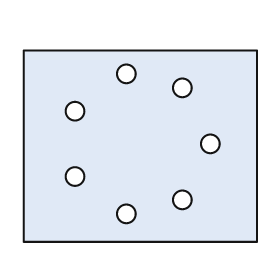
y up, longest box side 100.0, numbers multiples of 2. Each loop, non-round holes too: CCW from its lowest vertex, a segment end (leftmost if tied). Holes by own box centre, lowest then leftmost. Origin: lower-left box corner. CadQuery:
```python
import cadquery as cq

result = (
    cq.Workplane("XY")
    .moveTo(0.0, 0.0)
    .lineTo(100.0, 0.0)
    .lineTo(100.0, 82.0)
    .lineTo(0.0, 82.0)
    .close()
    .moveTo(44.0, 12.0)
    .circle(4.0)
    .moveTo(68.0, 18.0)
    .circle(4.0)
    .moveTo(22.0, 28.0)
    .circle(4.0)
    .moveTo(80.0, 42.0)
    .circle(4.0)
    .moveTo(22.0, 56.0)
    .circle(4.0)
    .moveTo(68.0, 66.0)
    .circle(4.0)
    .moveTo(44.0, 72.0)
    .circle(4.0)
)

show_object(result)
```